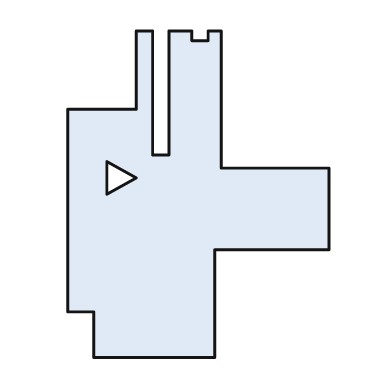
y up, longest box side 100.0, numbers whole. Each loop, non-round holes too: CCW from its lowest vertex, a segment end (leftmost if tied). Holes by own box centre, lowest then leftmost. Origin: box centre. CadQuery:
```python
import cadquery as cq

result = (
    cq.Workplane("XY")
    .moveTo(-32.0, -50.0)
    .lineTo(5.0, -50.0)
    .lineTo(5.0, -17.0)
    .lineTo(40.0, -17.0)
    .lineTo(40.0, 8.0)
    .lineTo(7.0, 8.0)
    .lineTo(7.0, 50.0)
    .lineTo(3.0, 50.0)
    .lineTo(3.0, 47.0)
    .lineTo(-2.0, 47.0)
    .lineTo(-2.0, 50.0)
    .lineTo(-9.0, 50.0)
    .lineTo(-9.0, 12.0)
    .lineTo(-14.0, 12.0)
    .lineTo(-14.0, 50.0)
    .lineTo(-19.0, 50.0)
    .lineTo(-19.0, 26.0)
    .lineTo(-40.0, 26.0)
    .lineTo(-40.0, -36.0)
    .lineTo(-32.0, -36.0)
    .close()
    .moveTo(-28.0, 0.0)
    .lineTo(-19.0, 5.0)
    .lineTo(-28.0, 10.0)
    .close()
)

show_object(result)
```